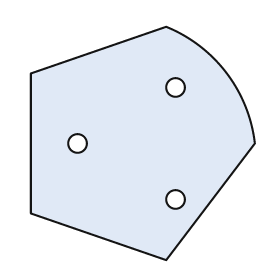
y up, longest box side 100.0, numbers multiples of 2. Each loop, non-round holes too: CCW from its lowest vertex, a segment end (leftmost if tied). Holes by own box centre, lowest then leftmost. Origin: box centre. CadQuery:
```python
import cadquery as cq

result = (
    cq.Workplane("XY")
    .moveTo(10.0, -50.0)
    .lineTo(48.0, 0.0)
    .threePointArc((36.0, 30.0), (10.0, 50.0))
    .lineTo(-48.0, 30.0)
    .lineTo(-48.0, -30.0)
    .close()
    .moveTo(14.0, -24.0)
    .circle(4.0)
    .moveTo(-28.0, 0.0)
    .circle(4.0)
    .moveTo(14.0, 24.0)
    .circle(4.0)
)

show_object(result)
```